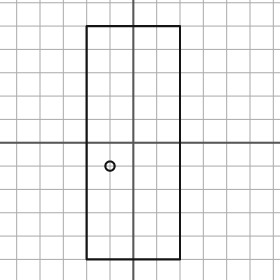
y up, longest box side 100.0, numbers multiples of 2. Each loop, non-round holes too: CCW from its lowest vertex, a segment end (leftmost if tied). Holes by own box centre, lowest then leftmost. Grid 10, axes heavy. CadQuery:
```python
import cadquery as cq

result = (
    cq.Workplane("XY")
    .moveTo(-20.0, -50.0)
    .lineTo(20.0, -50.0)
    .lineTo(20.0, 50.0)
    .lineTo(-20.0, 50.0)
    .close()
    .moveTo(-10.0, -10.0)
    .circle(2.0)
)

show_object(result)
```